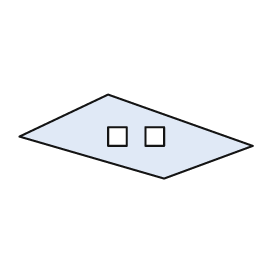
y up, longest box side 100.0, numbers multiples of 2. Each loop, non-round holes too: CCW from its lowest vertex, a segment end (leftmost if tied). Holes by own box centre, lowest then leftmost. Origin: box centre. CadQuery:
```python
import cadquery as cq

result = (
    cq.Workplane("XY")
    .moveTo(12.0, -18.0)
    .lineTo(50.0, -4.0)
    .lineTo(-12.0, 18.0)
    .lineTo(-50.0, 0.0)
    .close()
    .moveTo(-12.0, -4.0)
    .lineTo(-4.0, -4.0)
    .lineTo(-4.0, 4.0)
    .lineTo(-12.0, 4.0)
    .close()
    .moveTo(4.0, -4.0)
    .lineTo(12.0, -4.0)
    .lineTo(12.0, 4.0)
    .lineTo(4.0, 4.0)
    .close()
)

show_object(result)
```